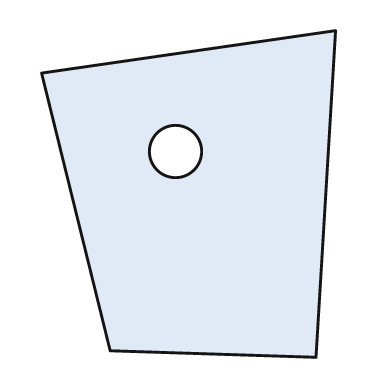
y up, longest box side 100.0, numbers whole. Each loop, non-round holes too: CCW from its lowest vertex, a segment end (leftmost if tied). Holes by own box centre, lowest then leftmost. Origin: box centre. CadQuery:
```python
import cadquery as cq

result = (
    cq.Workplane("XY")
    .moveTo(39.0, -50.0)
    .lineTo(45.0, 50.0)
    .lineTo(-45.0, 37.0)
    .lineTo(-24.0, -48.0)
    .close()
    .moveTo(-4.0, 13.0)
    .circle(8.0)
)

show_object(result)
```